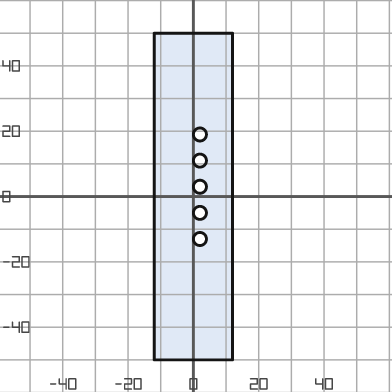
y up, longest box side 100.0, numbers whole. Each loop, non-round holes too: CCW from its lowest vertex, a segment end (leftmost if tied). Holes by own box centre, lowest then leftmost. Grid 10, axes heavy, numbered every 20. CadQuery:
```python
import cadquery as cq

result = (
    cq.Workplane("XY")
    .moveTo(-12.0, -50.0)
    .lineTo(12.0, -50.0)
    .lineTo(12.0, 50.0)
    .lineTo(-12.0, 50.0)
    .close()
    .moveTo(2.0, -13.0)
    .circle(2.0)
    .moveTo(2.0, -5.0)
    .circle(2.0)
    .moveTo(2.0, 3.0)
    .circle(2.0)
    .moveTo(2.0, 11.0)
    .circle(2.0)
    .moveTo(2.0, 19.0)
    .circle(2.0)
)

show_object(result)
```